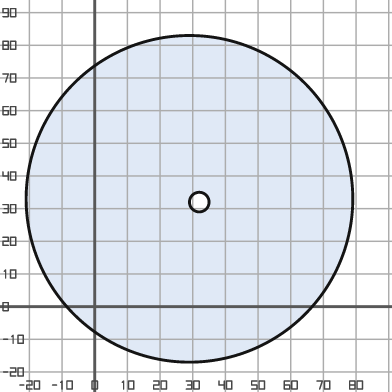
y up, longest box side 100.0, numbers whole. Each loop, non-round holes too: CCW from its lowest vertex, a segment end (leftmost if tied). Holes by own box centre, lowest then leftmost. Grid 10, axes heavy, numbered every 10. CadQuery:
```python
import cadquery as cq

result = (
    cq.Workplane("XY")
    .moveTo(29.0, 33.0)
    .circle(50.0)
    .moveTo(32.0, 32.0)
    .circle(3.0)
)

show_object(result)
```